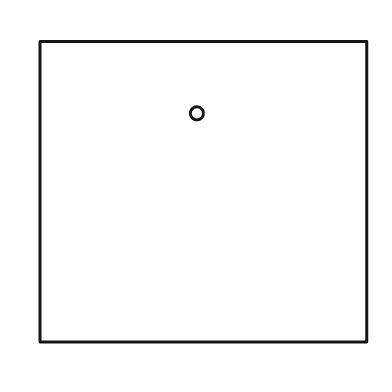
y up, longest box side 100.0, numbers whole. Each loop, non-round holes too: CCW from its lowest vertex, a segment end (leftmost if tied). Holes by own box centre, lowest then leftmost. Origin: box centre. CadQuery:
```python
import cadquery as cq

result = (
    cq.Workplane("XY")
    .moveTo(-50.0, -46.0)
    .lineTo(50.0, -46.0)
    .lineTo(50.0, 46.0)
    .lineTo(-50.0, 46.0)
    .close()
    .moveTo(-2.0, 24.0)
    .circle(2.0)
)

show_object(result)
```